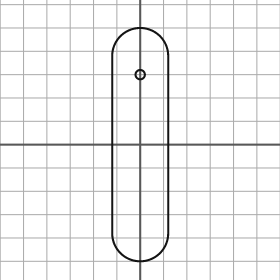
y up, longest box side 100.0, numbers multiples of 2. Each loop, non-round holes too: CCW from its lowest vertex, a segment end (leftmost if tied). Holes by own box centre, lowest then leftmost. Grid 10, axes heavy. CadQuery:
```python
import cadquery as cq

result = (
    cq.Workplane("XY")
    .moveTo(-12.0, -38.0)
    .threePointArc((0.0, -50.0), (12.0, -38.0))
    .lineTo(12.0, 38.0)
    .threePointArc((0.0, 50.0), (-12.0, 38.0))
    .close()
    .moveTo(0.0, 30.0)
    .circle(2.0)
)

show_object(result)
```